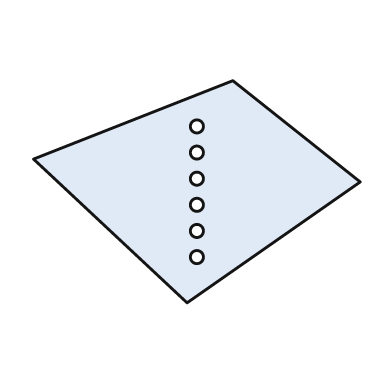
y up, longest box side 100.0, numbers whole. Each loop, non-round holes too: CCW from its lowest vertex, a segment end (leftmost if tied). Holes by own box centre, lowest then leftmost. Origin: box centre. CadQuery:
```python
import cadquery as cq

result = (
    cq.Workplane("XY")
    .moveTo(-3.0, -34.0)
    .lineTo(50.0, 3.0)
    .lineTo(11.0, 34.0)
    .lineTo(-50.0, 10.0)
    .close()
    .moveTo(0.0, -20.0)
    .circle(2.0)
    .moveTo(0.0, -12.0)
    .circle(2.0)
    .moveTo(0.0, -4.0)
    .circle(2.0)
    .moveTo(0.0, 4.0)
    .circle(2.0)
    .moveTo(0.0, 12.0)
    .circle(2.0)
    .moveTo(0.0, 20.0)
    .circle(2.0)
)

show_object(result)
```